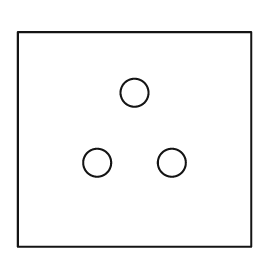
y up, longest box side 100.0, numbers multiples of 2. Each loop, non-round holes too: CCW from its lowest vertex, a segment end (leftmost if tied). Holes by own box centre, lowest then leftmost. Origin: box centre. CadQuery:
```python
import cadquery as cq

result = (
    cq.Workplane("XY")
    .moveTo(-50.0, -46.0)
    .lineTo(50.0, -46.0)
    .lineTo(50.0, 46.0)
    .lineTo(-50.0, 46.0)
    .close()
    .moveTo(-16.0, -10.0)
    .circle(6.0)
    .moveTo(16.0, -10.0)
    .circle(6.0)
    .moveTo(0.0, 20.0)
    .circle(6.0)
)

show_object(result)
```